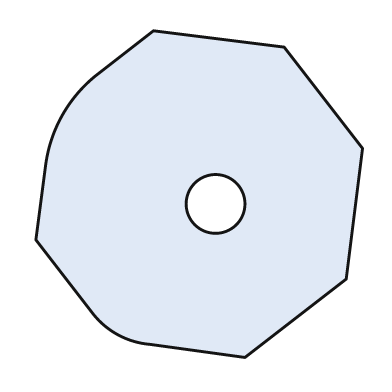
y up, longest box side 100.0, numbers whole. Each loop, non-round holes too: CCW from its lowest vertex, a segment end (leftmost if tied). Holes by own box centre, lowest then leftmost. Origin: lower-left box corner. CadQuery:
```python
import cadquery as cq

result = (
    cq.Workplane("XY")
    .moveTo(64.0, 0.0)
    .lineTo(95.0, 24.0)
    .lineTo(100.0, 64.0)
    .lineTo(76.0, 95.0)
    .lineTo(36.0, 100.0)
    .lineTo(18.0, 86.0)
    .threePointArc((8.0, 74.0), (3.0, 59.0))
    .lineTo(0.0, 36.0)
    .lineTo(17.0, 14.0)
    .threePointArc((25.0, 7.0), (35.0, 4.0))
    .close()
    .moveTo(55.0, 47.0)
    .circle(9.0)
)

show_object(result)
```